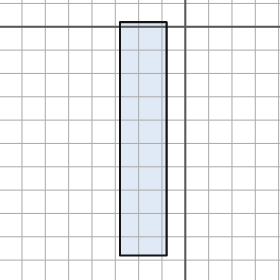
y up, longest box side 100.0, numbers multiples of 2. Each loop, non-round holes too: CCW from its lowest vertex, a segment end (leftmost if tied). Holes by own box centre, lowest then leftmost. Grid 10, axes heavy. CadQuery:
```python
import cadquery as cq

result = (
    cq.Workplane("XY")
    .moveTo(-28.0, -98.0)
    .lineTo(-8.0, -98.0)
    .lineTo(-8.0, 2.0)
    .lineTo(-28.0, 2.0)
    .close()
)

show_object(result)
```